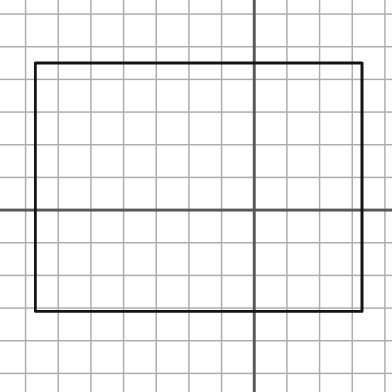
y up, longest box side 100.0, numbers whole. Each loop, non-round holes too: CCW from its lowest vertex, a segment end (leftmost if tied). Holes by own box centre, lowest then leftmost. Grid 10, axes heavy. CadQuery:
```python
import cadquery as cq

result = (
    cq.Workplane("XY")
    .moveTo(-67.0, -31.0)
    .lineTo(33.0, -31.0)
    .lineTo(33.0, 45.0)
    .lineTo(-67.0, 45.0)
    .close()
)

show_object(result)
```